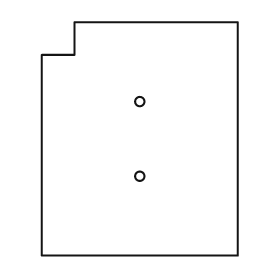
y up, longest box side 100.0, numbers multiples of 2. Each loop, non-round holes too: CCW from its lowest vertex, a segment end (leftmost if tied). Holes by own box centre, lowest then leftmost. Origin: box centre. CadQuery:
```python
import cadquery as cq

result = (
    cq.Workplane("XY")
    .moveTo(-42.0, -50.0)
    .lineTo(42.0, -50.0)
    .lineTo(42.0, 50.0)
    .lineTo(-28.0, 50.0)
    .lineTo(-28.0, 36.0)
    .lineTo(-42.0, 36.0)
    .close()
    .moveTo(0.0, -16.0)
    .circle(2.0)
    .moveTo(0.0, 16.0)
    .circle(2.0)
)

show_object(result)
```